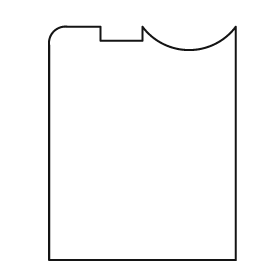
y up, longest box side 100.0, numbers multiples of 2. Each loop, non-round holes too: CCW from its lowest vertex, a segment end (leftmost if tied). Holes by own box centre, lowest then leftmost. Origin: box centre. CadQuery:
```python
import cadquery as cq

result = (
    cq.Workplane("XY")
    .moveTo(-40.0, -50.0)
    .lineTo(40.0, -50.0)
    .lineTo(40.0, 50.0)
    .threePointArc((20.0, 40.0), (0.0, 50.0))
    .lineTo(0.0, 44.0)
    .lineTo(-18.0, 44.0)
    .lineTo(-18.0, 50.0)
    .lineTo(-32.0, 50.0)
    .threePointArc((-38.0, 48.0), (-40.0, 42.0))
    .close()
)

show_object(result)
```